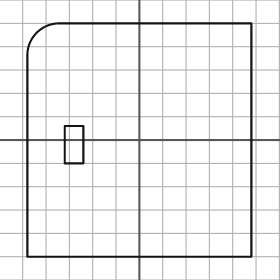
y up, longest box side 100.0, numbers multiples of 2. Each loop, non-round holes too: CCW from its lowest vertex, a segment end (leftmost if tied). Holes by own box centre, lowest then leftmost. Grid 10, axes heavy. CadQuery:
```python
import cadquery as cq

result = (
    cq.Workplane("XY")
    .moveTo(-48.0, -50.0)
    .lineTo(48.0, -50.0)
    .lineTo(48.0, 50.0)
    .lineTo(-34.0, 50.0)
    .threePointArc((-44.0, 46.0), (-48.0, 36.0))
    .close()
    .moveTo(-32.0, -10.0)
    .lineTo(-24.0, -10.0)
    .lineTo(-24.0, 6.0)
    .lineTo(-32.0, 6.0)
    .close()
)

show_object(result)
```